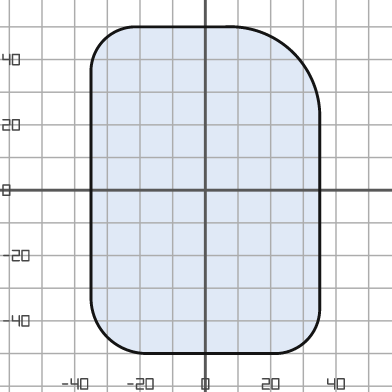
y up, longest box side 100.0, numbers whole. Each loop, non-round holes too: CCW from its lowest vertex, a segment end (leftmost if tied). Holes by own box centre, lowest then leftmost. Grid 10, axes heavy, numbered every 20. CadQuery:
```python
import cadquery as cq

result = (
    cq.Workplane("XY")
    .moveTo(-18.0, -50.0)
    .lineTo(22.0, -50.0)
    .threePointArc((31.0, -46.0), (35.0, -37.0))
    .lineTo(35.0, 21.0)
    .threePointArc((27.0, 42.0), (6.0, 50.0))
    .lineTo(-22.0, 50.0)
    .threePointArc((-31.0, 46.0), (-35.0, 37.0))
    .lineTo(-35.0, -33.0)
    .threePointArc((-30.0, -45.0), (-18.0, -50.0))
    .close()
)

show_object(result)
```